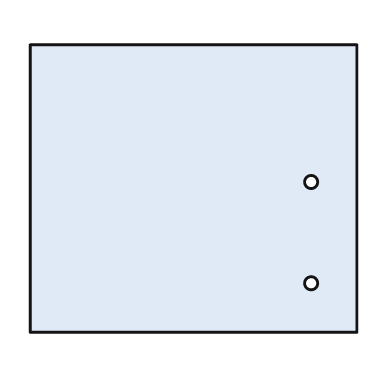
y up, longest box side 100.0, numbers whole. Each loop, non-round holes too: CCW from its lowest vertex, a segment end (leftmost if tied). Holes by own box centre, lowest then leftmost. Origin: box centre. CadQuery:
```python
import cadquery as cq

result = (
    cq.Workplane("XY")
    .moveTo(-50.0, -44.0)
    .lineTo(50.0, -44.0)
    .lineTo(50.0, 44.0)
    .lineTo(-50.0, 44.0)
    .close()
    .moveTo(36.0, -29.0)
    .circle(2.0)
    .moveTo(36.0, 2.0)
    .circle(2.0)
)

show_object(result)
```